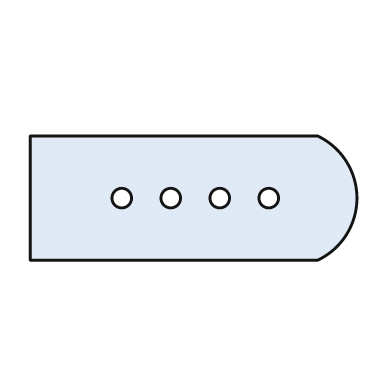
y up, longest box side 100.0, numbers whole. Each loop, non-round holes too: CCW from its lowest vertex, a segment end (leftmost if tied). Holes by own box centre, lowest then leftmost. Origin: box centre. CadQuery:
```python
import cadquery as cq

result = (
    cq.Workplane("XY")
    .moveTo(-50.0, -19.0)
    .lineTo(38.0, -19.0)
    .threePointArc((50.0, 0.0), (38.0, 19.0))
    .lineTo(-50.0, 19.0)
    .close()
    .moveTo(-22.0, 0.0)
    .circle(3.0)
    .moveTo(-7.0, 0.0)
    .circle(3.0)
    .moveTo(8.0, 0.0)
    .circle(3.0)
    .moveTo(23.0, 0.0)
    .circle(3.0)
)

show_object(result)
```